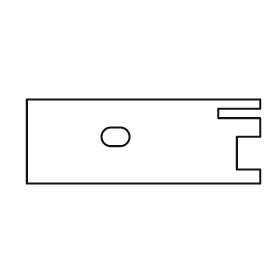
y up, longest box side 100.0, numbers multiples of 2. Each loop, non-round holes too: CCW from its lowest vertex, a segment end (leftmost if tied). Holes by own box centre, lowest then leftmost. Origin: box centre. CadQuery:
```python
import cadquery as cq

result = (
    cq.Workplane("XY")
    .moveTo(-50.0, -18.0)
    .lineTo(50.0, -18.0)
    .lineTo(50.0, -12.0)
    .lineTo(40.0, -12.0)
    .lineTo(40.0, 2.0)
    .lineTo(50.0, 2.0)
    .lineTo(50.0, 10.0)
    .lineTo(32.0, 10.0)
    .lineTo(32.0, 14.0)
    .lineTo(50.0, 14.0)
    .lineTo(50.0, 18.0)
    .lineTo(-50.0, 18.0)
    .close()
    .moveTo(-14.0, -2.0)
    .lineTo(-10.0, -2.0)
    .threePointArc((-6.0, 2.0), (-10.0, 6.0))
    .lineTo(-14.0, 6.0)
    .threePointArc((-18.0, 2.0), (-14.0, -2.0))
    .close()
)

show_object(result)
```